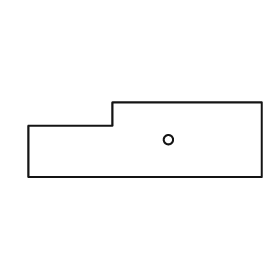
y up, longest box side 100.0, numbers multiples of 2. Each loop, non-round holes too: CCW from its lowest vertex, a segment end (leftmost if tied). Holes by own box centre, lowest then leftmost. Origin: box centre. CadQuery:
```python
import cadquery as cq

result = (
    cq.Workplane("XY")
    .moveTo(-50.0, -16.0)
    .lineTo(50.0, -16.0)
    .lineTo(50.0, 16.0)
    .lineTo(-14.0, 16.0)
    .lineTo(-14.0, 6.0)
    .lineTo(-50.0, 6.0)
    .close()
    .moveTo(10.0, 0.0)
    .circle(2.0)
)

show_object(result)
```